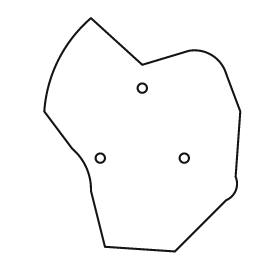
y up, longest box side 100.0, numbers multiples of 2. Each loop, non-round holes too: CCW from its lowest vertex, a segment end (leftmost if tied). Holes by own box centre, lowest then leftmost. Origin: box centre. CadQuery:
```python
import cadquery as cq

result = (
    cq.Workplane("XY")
    .moveTo(14.0, -50.0)
    .lineTo(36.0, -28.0)
    .threePointArc((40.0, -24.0), (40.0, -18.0))
    .lineTo(42.0, 10.0)
    .lineTo(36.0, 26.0)
    .threePointArc((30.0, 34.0), (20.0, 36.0))
    .lineTo(0.0, 30.0)
    .lineTo(-22.0, 50.0)
    .threePointArc((-36.0, 32.0), (-42.0, 10.0))
    .lineTo(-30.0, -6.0)
    .threePointArc((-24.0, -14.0), (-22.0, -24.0))
    .lineTo(-16.0, -48.0)
    .close()
    .moveTo(-18.0, -10.0)
    .circle(2.0)
    .moveTo(18.0, -10.0)
    .circle(2.0)
    .moveTo(0.0, 20.0)
    .circle(2.0)
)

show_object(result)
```